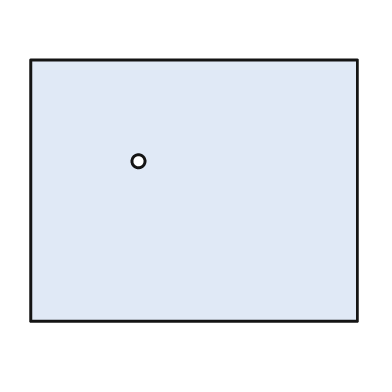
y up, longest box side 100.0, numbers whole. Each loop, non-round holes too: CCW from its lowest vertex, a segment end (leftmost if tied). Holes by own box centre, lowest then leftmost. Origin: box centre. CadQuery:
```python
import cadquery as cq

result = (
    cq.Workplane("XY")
    .moveTo(-50.0, -40.0)
    .lineTo(50.0, -40.0)
    .lineTo(50.0, 40.0)
    .lineTo(-50.0, 40.0)
    .close()
    .moveTo(-17.0, 9.0)
    .circle(2.0)
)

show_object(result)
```